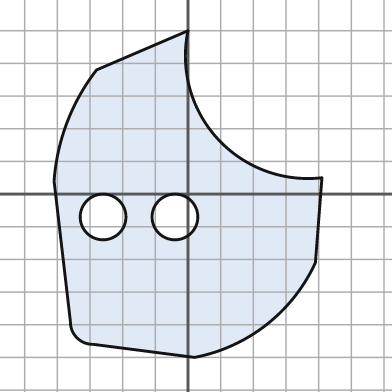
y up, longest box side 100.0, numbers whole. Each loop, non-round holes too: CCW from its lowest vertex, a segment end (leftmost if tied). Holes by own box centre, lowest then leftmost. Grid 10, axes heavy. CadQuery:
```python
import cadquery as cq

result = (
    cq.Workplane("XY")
    .moveTo(2.0, -50.0)
    .threePointArc((24.0, -40.0), (39.0, -21.0))
    .lineTo(41.0, 5.0)
    .threePointArc((9.0, 17.0), (0.0, 50.0))
    .lineTo(-28.0, 38.0)
    .threePointArc((-37.0, 22.0), (-41.0, 4.0))
    .lineTo(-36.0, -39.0)
    .threePointArc((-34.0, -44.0), (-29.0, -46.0))
    .close()
    .moveTo(-26.0, -7.0)
    .circle(7.0)
    .moveTo(-4.0, -7.0)
    .circle(7.0)
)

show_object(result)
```